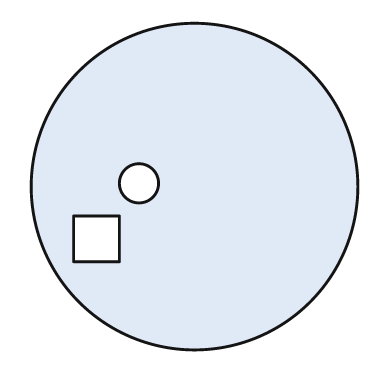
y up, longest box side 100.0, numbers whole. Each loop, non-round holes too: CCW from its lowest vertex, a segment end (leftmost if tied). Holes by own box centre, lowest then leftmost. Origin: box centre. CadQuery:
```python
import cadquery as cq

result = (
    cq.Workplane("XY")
    .moveTo(0.0, 0.0)
    .circle(50.0)
    .moveTo(-37.0, -23.0)
    .lineTo(-23.0, -23.0)
    .lineTo(-23.0, -9.0)
    .lineTo(-37.0, -9.0)
    .close()
    .moveTo(-17.0, 1.0)
    .circle(6.0)
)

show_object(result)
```